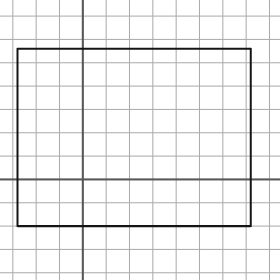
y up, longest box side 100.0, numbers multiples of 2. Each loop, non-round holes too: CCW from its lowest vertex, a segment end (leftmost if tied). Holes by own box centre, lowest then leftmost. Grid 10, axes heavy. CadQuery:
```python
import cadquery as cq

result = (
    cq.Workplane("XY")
    .moveTo(-28.0, -20.0)
    .lineTo(72.0, -20.0)
    .lineTo(72.0, 56.0)
    .lineTo(-28.0, 56.0)
    .close()
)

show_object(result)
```